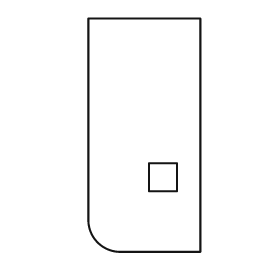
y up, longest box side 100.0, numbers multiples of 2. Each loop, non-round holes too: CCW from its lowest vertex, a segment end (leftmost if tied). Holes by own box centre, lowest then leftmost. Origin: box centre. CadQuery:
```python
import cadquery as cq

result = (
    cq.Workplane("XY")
    .moveTo(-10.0, -50.0)
    .lineTo(24.0, -50.0)
    .lineTo(24.0, 50.0)
    .lineTo(-24.0, 50.0)
    .lineTo(-24.0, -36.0)
    .threePointArc((-20.0, -46.0), (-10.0, -50.0))
    .close()
    .moveTo(2.0, -24.0)
    .lineTo(14.0, -24.0)
    .lineTo(14.0, -12.0)
    .lineTo(2.0, -12.0)
    .close()
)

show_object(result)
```